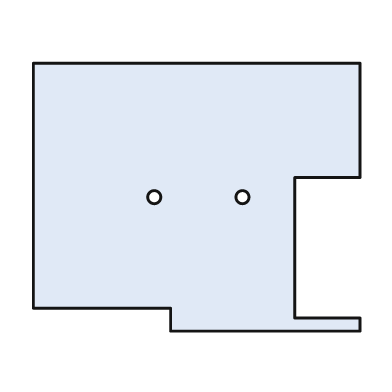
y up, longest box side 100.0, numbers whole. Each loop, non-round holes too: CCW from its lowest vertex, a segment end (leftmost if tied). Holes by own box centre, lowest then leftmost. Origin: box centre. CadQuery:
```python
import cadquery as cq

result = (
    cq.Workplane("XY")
    .moveTo(-8.0, -41.0)
    .lineTo(50.0, -41.0)
    .lineTo(50.0, -37.0)
    .lineTo(30.0, -37.0)
    .lineTo(30.0, 6.0)
    .lineTo(50.0, 6.0)
    .lineTo(50.0, 41.0)
    .lineTo(-50.0, 41.0)
    .lineTo(-50.0, -34.0)
    .lineTo(-8.0, -34.0)
    .close()
    .moveTo(-13.0, 0.0)
    .circle(2.0)
    .moveTo(14.0, 0.0)
    .circle(2.0)
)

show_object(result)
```